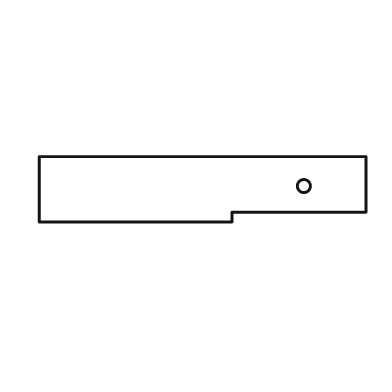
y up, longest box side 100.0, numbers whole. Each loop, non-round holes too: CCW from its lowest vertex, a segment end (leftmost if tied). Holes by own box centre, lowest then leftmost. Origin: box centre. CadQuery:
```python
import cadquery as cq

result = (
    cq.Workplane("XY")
    .moveTo(-50.0, -10.0)
    .lineTo(9.0, -10.0)
    .lineTo(9.0, -7.0)
    .lineTo(50.0, -7.0)
    .lineTo(50.0, 10.0)
    .lineTo(-50.0, 10.0)
    .close()
    .moveTo(31.0, 1.0)
    .circle(2.0)
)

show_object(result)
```